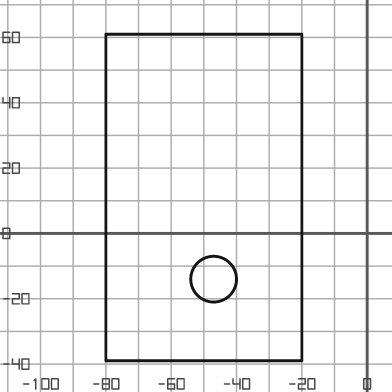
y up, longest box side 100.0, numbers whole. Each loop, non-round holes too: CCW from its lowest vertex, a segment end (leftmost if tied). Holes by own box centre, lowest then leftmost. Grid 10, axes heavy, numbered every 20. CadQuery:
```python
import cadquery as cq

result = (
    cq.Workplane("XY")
    .moveTo(-80.0, -39.0)
    .lineTo(-20.0, -39.0)
    .lineTo(-20.0, 61.0)
    .lineTo(-80.0, 61.0)
    .close()
    .moveTo(-47.0, -14.0)
    .circle(7.0)
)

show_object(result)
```